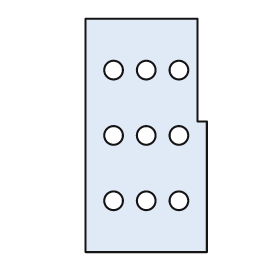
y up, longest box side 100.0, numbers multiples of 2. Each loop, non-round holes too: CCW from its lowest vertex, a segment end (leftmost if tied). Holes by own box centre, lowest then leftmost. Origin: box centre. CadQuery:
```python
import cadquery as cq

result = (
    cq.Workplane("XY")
    .moveTo(-26.0, -50.0)
    .lineTo(26.0, -50.0)
    .lineTo(26.0, 6.0)
    .lineTo(22.0, 6.0)
    .lineTo(22.0, 50.0)
    .lineTo(-26.0, 50.0)
    .close()
    .moveTo(-14.0, -28.0)
    .circle(4.0)
    .moveTo(0.0, -28.0)
    .circle(4.0)
    .moveTo(14.0, -28.0)
    .circle(4.0)
    .moveTo(-14.0, 0.0)
    .circle(4.0)
    .moveTo(0.0, 0.0)
    .circle(4.0)
    .moveTo(14.0, 0.0)
    .circle(4.0)
    .moveTo(-14.0, 28.0)
    .circle(4.0)
    .moveTo(0.0, 28.0)
    .circle(4.0)
    .moveTo(14.0, 28.0)
    .circle(4.0)
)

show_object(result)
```